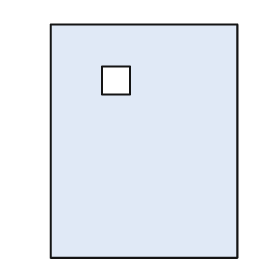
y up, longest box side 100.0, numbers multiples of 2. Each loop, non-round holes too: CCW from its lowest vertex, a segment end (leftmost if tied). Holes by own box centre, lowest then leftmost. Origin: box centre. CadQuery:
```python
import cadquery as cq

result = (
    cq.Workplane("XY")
    .moveTo(-40.0, -50.0)
    .lineTo(40.0, -50.0)
    .lineTo(40.0, 50.0)
    .lineTo(-40.0, 50.0)
    .close()
    .moveTo(-18.0, 20.0)
    .lineTo(-6.0, 20.0)
    .lineTo(-6.0, 32.0)
    .lineTo(-18.0, 32.0)
    .close()
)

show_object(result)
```